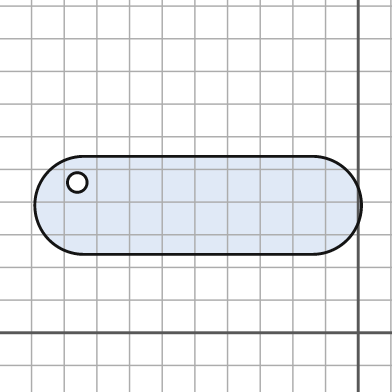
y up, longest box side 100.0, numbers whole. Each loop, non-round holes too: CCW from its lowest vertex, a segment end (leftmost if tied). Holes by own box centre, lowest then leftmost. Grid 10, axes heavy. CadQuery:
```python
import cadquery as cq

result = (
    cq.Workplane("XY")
    .moveTo(-84.0, 24.0)
    .lineTo(-14.0, 24.0)
    .threePointArc((1.0, 39.0), (-14.0, 54.0))
    .lineTo(-84.0, 54.0)
    .threePointArc((-99.0, 39.0), (-84.0, 24.0))
    .close()
    .moveTo(-86.0, 46.0)
    .circle(3.0)
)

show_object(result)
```